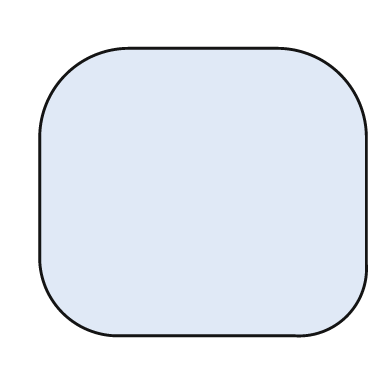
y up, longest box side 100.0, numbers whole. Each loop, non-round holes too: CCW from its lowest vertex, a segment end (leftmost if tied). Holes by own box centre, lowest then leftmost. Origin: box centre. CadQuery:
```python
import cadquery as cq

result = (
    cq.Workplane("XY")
    .moveTo(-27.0, -44.0)
    .lineTo(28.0, -44.0)
    .threePointArc((44.0, -38.0), (50.0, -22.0))
    .lineTo(50.0, 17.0)
    .threePointArc((42.0, 36.0), (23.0, 44.0))
    .lineTo(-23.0, 44.0)
    .threePointArc((-42.0, 36.0), (-50.0, 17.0))
    .lineTo(-50.0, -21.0)
    .threePointArc((-43.0, -37.0), (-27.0, -44.0))
    .close()
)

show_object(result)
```